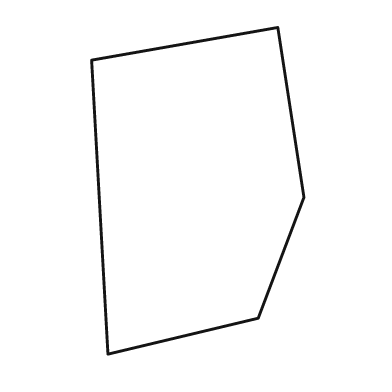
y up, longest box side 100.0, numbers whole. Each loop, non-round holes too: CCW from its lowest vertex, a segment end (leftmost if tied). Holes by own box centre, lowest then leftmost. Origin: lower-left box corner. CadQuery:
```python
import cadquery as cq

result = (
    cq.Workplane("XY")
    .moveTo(5.0, 0.0)
    .lineTo(51.0, 11.0)
    .lineTo(65.0, 48.0)
    .lineTo(57.0, 100.0)
    .lineTo(0.0, 90.0)
    .close()
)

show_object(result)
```